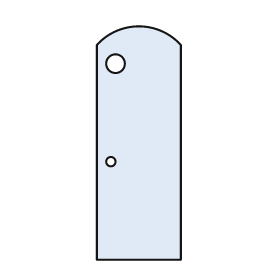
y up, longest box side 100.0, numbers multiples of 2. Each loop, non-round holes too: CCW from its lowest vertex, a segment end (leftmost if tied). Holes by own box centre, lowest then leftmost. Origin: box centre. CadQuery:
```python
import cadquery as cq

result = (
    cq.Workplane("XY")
    .moveTo(-18.0, -50.0)
    .lineTo(18.0, -50.0)
    .lineTo(18.0, 42.0)
    .threePointArc((0.0, 50.0), (-18.0, 42.0))
    .close()
    .moveTo(-12.0, -8.0)
    .circle(2.0)
    .moveTo(-10.0, 34.0)
    .circle(4.0)
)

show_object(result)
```